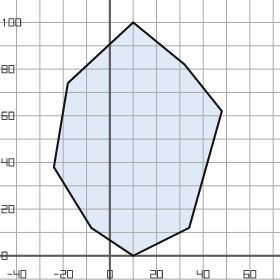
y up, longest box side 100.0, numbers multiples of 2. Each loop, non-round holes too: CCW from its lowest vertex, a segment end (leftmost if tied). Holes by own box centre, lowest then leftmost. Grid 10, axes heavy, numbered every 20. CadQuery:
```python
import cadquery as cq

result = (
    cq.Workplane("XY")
    .moveTo(10.0, 0.0)
    .lineTo(34.0, 12.0)
    .lineTo(48.0, 62.0)
    .lineTo(32.0, 82.0)
    .lineTo(10.0, 100.0)
    .lineTo(-18.0, 74.0)
    .lineTo(-24.0, 38.0)
    .lineTo(-8.0, 12.0)
    .close()
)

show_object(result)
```